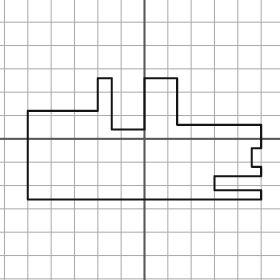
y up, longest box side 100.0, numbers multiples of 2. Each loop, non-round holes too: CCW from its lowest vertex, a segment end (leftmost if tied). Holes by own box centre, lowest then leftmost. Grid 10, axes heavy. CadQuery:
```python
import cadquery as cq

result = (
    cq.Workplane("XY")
    .moveTo(-50.0, -26.0)
    .lineTo(50.0, -26.0)
    .lineTo(50.0, -22.0)
    .lineTo(30.0, -22.0)
    .lineTo(30.0, -16.0)
    .lineTo(50.0, -16.0)
    .lineTo(50.0, -12.0)
    .lineTo(46.0, -12.0)
    .lineTo(46.0, -4.0)
    .lineTo(50.0, -4.0)
    .lineTo(50.0, 6.0)
    .lineTo(14.0, 6.0)
    .lineTo(14.0, 26.0)
    .lineTo(0.0, 26.0)
    .lineTo(0.0, 4.0)
    .lineTo(-14.0, 4.0)
    .lineTo(-14.0, 26.0)
    .lineTo(-20.0, 26.0)
    .lineTo(-20.0, 12.0)
    .lineTo(-50.0, 12.0)
    .close()
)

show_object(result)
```